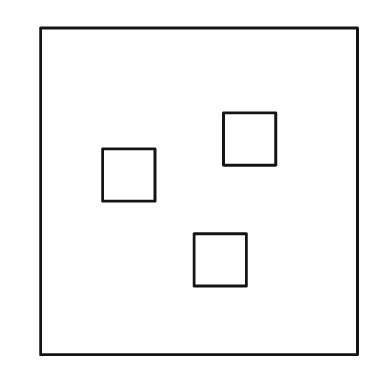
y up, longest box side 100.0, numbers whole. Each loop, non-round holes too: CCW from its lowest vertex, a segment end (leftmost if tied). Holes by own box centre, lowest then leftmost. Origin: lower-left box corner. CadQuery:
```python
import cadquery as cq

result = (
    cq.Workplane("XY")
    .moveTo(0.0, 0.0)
    .lineTo(97.0, 0.0)
    .lineTo(97.0, 100.0)
    .lineTo(0.0, 100.0)
    .close()
    .moveTo(47.0, 21.0)
    .lineTo(63.0, 21.0)
    .lineTo(63.0, 37.0)
    .lineTo(47.0, 37.0)
    .close()
    .moveTo(19.0, 47.0)
    .lineTo(35.0, 47.0)
    .lineTo(35.0, 63.0)
    .lineTo(19.0, 63.0)
    .close()
    .moveTo(56.0, 58.0)
    .lineTo(72.0, 58.0)
    .lineTo(72.0, 74.0)
    .lineTo(56.0, 74.0)
    .close()
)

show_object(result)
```